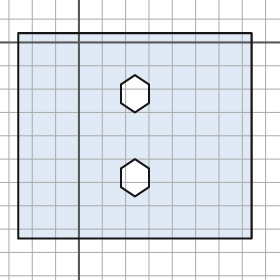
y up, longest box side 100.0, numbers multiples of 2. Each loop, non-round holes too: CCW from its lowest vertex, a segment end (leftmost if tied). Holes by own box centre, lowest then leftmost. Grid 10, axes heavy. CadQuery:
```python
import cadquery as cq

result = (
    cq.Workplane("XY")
    .moveTo(-26.0, -84.0)
    .lineTo(74.0, -84.0)
    .lineTo(74.0, 4.0)
    .lineTo(-26.0, 4.0)
    .close()
    .moveTo(24.0, -66.0)
    .lineTo(30.0, -62.0)
    .lineTo(30.0, -54.0)
    .lineTo(24.0, -50.0)
    .lineTo(18.0, -54.0)
    .lineTo(18.0, -62.0)
    .close()
    .moveTo(24.0, -30.0)
    .lineTo(30.0, -26.0)
    .lineTo(30.0, -18.0)
    .lineTo(24.0, -14.0)
    .lineTo(18.0, -18.0)
    .lineTo(18.0, -26.0)
    .close()
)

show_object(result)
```